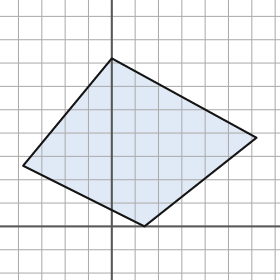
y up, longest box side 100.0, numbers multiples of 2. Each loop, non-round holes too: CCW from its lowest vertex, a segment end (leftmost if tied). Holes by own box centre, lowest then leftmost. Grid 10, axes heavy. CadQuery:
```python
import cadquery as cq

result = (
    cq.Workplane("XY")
    .moveTo(14.0, 0.0)
    .lineTo(62.0, 38.0)
    .lineTo(0.0, 72.0)
    .lineTo(-38.0, 26.0)
    .close()
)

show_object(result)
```